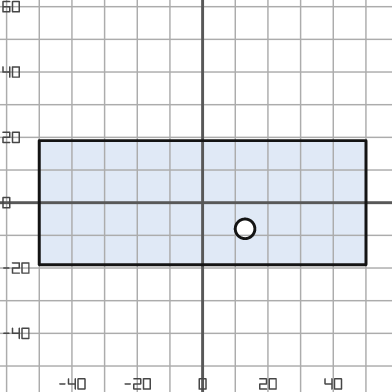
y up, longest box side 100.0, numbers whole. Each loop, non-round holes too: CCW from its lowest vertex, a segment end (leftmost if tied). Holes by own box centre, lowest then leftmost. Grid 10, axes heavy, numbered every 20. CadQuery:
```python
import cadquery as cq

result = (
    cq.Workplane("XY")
    .moveTo(-50.0, -19.0)
    .lineTo(50.0, -19.0)
    .lineTo(50.0, 19.0)
    .lineTo(-50.0, 19.0)
    .close()
    .moveTo(13.0, -8.0)
    .circle(3.0)
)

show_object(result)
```